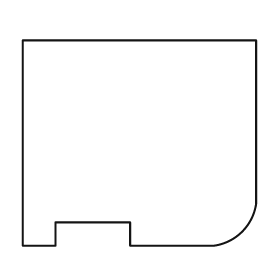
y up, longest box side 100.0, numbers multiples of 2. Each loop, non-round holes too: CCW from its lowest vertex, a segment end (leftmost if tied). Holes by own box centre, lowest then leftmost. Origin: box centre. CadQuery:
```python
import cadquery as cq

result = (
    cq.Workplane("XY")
    .moveTo(-50.0, -44.0)
    .lineTo(-36.0, -44.0)
    .lineTo(-36.0, -34.0)
    .lineTo(-4.0, -34.0)
    .lineTo(-4.0, -44.0)
    .lineTo(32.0, -44.0)
    .threePointArc((44.0, -38.0), (50.0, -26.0))
    .lineTo(50.0, 44.0)
    .lineTo(-50.0, 44.0)
    .close()
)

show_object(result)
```